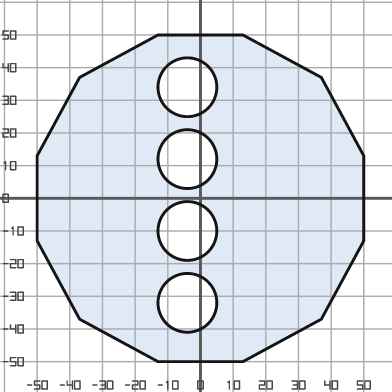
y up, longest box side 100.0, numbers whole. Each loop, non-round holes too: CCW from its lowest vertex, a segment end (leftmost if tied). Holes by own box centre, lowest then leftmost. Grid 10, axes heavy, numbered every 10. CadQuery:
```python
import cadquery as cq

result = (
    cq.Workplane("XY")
    .moveTo(-13.0, -50.0)
    .lineTo(13.0, -50.0)
    .lineTo(37.0, -37.0)
    .lineTo(50.0, -13.0)
    .lineTo(50.0, 13.0)
    .lineTo(37.0, 37.0)
    .lineTo(13.0, 50.0)
    .lineTo(-13.0, 50.0)
    .lineTo(-37.0, 37.0)
    .lineTo(-50.0, 13.0)
    .lineTo(-50.0, -13.0)
    .lineTo(-37.0, -37.0)
    .close()
    .moveTo(-4.0, -32.0)
    .circle(9.0)
    .moveTo(-4.0, -10.0)
    .circle(9.0)
    .moveTo(-4.0, 12.0)
    .circle(9.0)
    .moveTo(-4.0, 34.0)
    .circle(9.0)
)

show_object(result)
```